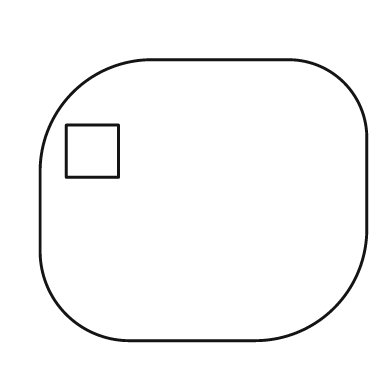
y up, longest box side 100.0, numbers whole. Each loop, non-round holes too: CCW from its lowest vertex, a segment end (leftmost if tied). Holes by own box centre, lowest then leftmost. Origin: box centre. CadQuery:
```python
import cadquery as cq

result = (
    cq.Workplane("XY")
    .moveTo(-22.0, -43.0)
    .lineTo(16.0, -43.0)
    .threePointArc((40.0, -33.0), (50.0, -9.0))
    .lineTo(50.0, 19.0)
    .threePointArc((43.0, 36.0), (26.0, 43.0))
    .lineTo(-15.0, 43.0)
    .threePointArc((-40.0, 33.0), (-50.0, 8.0))
    .lineTo(-50.0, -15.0)
    .threePointArc((-42.0, -35.0), (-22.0, -43.0))
    .close()
    .moveTo(-42.0, 7.0)
    .lineTo(-26.0, 7.0)
    .lineTo(-26.0, 23.0)
    .lineTo(-42.0, 23.0)
    .close()
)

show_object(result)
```